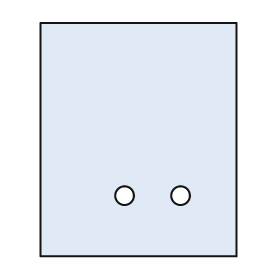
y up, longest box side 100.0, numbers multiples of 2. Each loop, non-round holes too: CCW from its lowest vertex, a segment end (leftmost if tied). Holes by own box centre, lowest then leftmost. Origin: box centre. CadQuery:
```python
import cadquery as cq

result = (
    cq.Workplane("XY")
    .moveTo(-42.0, -50.0)
    .lineTo(42.0, -50.0)
    .lineTo(42.0, 50.0)
    .lineTo(-42.0, 50.0)
    .close()
    .moveTo(-6.0, -24.0)
    .circle(4.0)
    .moveTo(18.0, -24.0)
    .circle(4.0)
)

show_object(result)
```